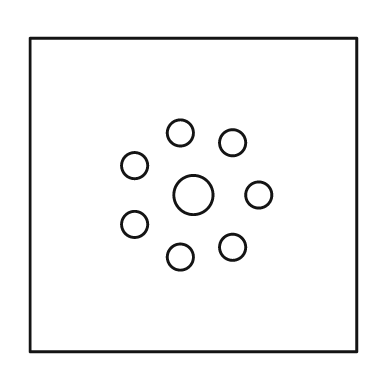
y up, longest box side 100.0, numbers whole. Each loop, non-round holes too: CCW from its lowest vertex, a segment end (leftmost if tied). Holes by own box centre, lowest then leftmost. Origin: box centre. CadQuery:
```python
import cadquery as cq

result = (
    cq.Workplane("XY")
    .moveTo(-50.0, -48.0)
    .lineTo(50.0, -48.0)
    .lineTo(50.0, 48.0)
    .lineTo(-50.0, 48.0)
    .close()
    .moveTo(-4.0, -19.0)
    .circle(4.0)
    .moveTo(12.0, -16.0)
    .circle(4.0)
    .moveTo(-18.0, -9.0)
    .circle(4.0)
    .moveTo(0.0, 0.0)
    .circle(6.0)
    .moveTo(20.0, 0.0)
    .circle(4.0)
    .moveTo(-18.0, 9.0)
    .circle(4.0)
    .moveTo(12.0, 16.0)
    .circle(4.0)
    .moveTo(-4.0, 19.0)
    .circle(4.0)
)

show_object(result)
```